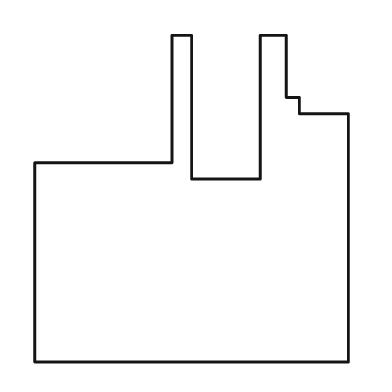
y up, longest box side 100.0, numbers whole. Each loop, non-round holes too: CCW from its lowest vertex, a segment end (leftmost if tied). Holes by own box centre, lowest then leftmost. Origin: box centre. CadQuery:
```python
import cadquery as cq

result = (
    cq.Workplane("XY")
    .moveTo(-48.0, -50.0)
    .lineTo(48.0, -50.0)
    .lineTo(48.0, 26.0)
    .lineTo(33.0, 26.0)
    .lineTo(33.0, 31.0)
    .lineTo(29.0, 31.0)
    .lineTo(29.0, 50.0)
    .lineTo(21.0, 50.0)
    .lineTo(21.0, 6.0)
    .lineTo(0.0, 6.0)
    .lineTo(0.0, 50.0)
    .lineTo(-6.0, 50.0)
    .lineTo(-6.0, 11.0)
    .lineTo(-48.0, 11.0)
    .close()
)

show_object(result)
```